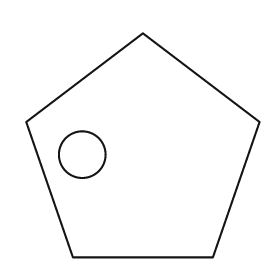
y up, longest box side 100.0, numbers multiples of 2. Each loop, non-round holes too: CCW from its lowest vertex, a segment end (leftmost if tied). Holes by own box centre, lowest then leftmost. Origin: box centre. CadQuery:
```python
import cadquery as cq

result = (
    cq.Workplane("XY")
    .moveTo(-30.0, -48.0)
    .lineTo(30.0, -48.0)
    .lineTo(50.0, 10.0)
    .lineTo(0.0, 48.0)
    .lineTo(-50.0, 10.0)
    .close()
    .moveTo(-26.0, -4.0)
    .circle(10.0)
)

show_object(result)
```